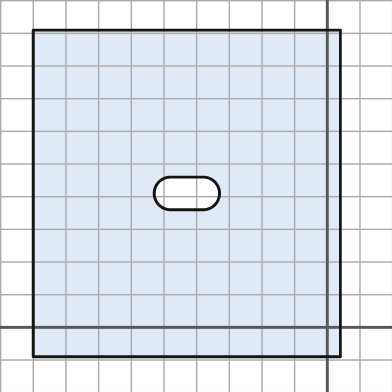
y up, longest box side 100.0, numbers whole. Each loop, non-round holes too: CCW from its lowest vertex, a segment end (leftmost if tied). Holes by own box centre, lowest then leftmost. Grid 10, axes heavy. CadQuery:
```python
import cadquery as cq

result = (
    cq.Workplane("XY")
    .moveTo(-90.0, -9.0)
    .lineTo(4.0, -9.0)
    .lineTo(4.0, 91.0)
    .lineTo(-90.0, 91.0)
    .close()
    .moveTo(-48.0, 36.0)
    .lineTo(-38.0, 36.0)
    .threePointArc((-33.0, 41.0), (-38.0, 46.0))
    .lineTo(-48.0, 46.0)
    .threePointArc((-53.0, 41.0), (-48.0, 36.0))
    .close()
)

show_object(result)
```